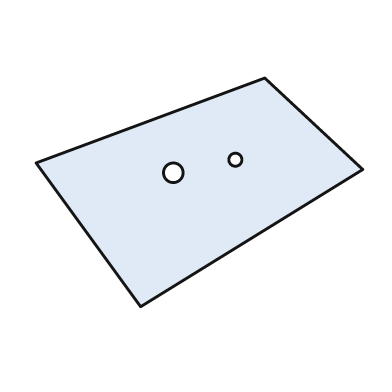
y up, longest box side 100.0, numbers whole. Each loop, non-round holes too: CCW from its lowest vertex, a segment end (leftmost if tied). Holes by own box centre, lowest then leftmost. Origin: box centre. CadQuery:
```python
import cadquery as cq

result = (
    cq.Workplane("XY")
    .moveTo(-18.0, -35.0)
    .lineTo(50.0, 7.0)
    .lineTo(20.0, 35.0)
    .lineTo(-50.0, 9.0)
    .close()
    .moveTo(-8.0, 6.0)
    .circle(3.0)
    .moveTo(11.0, 10.0)
    .circle(2.0)
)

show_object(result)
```